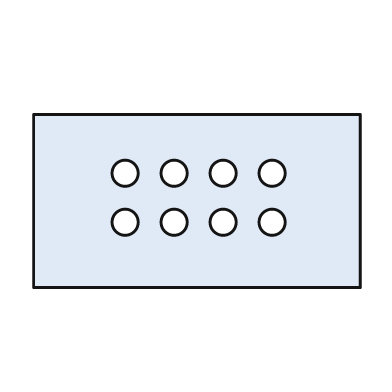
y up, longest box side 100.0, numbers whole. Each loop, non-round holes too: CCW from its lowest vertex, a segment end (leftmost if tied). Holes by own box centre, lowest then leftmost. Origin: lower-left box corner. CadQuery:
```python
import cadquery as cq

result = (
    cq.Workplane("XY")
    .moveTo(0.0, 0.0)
    .lineTo(100.0, 0.0)
    .lineTo(100.0, 53.0)
    .lineTo(0.0, 53.0)
    .close()
    .moveTo(28.0, 20.0)
    .circle(4.0)
    .moveTo(43.0, 20.0)
    .circle(4.0)
    .moveTo(58.0, 20.0)
    .circle(4.0)
    .moveTo(73.0, 20.0)
    .circle(4.0)
    .moveTo(28.0, 35.0)
    .circle(4.0)
    .moveTo(43.0, 35.0)
    .circle(4.0)
    .moveTo(58.0, 35.0)
    .circle(4.0)
    .moveTo(73.0, 35.0)
    .circle(4.0)
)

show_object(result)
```